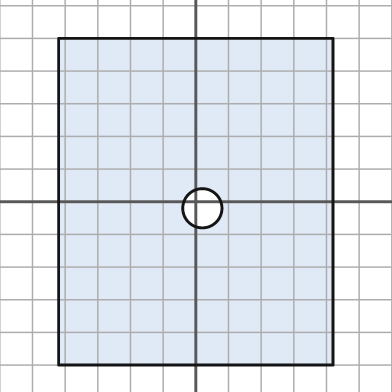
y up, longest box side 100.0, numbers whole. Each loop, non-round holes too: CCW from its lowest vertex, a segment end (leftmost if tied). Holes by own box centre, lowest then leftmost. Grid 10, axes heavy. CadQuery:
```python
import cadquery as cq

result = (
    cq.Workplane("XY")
    .moveTo(-42.0, -50.0)
    .lineTo(42.0, -50.0)
    .lineTo(42.0, 50.0)
    .lineTo(-42.0, 50.0)
    .close()
    .moveTo(2.0, -2.0)
    .circle(6.0)
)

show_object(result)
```